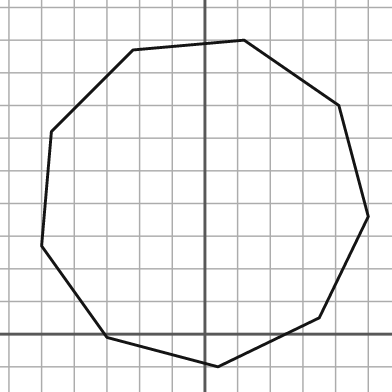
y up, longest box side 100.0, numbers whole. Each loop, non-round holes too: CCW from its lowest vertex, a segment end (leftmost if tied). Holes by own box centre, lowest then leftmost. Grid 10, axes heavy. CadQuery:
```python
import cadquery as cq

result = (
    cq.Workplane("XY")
    .moveTo(4.0, -10.0)
    .lineTo(35.0, 5.0)
    .lineTo(50.0, 36.0)
    .lineTo(41.0, 70.0)
    .lineTo(12.0, 90.0)
    .lineTo(-22.0, 87.0)
    .lineTo(-47.0, 62.0)
    .lineTo(-50.0, 27.0)
    .lineTo(-30.0, -1.0)
    .close()
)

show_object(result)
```